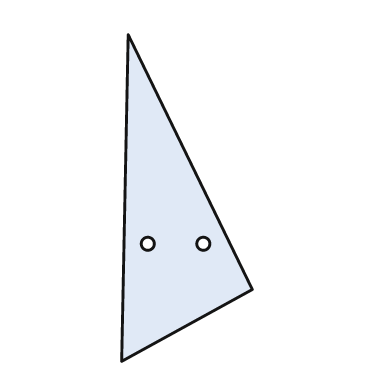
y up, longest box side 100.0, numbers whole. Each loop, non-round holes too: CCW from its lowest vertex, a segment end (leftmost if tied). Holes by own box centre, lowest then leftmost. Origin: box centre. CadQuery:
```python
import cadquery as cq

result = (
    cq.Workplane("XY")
    .moveTo(-20.0, -50.0)
    .lineTo(20.0, -28.0)
    .lineTo(-18.0, 50.0)
    .close()
    .moveTo(-12.0, -14.0)
    .circle(2.0)
    .moveTo(5.0, -14.0)
    .circle(2.0)
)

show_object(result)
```